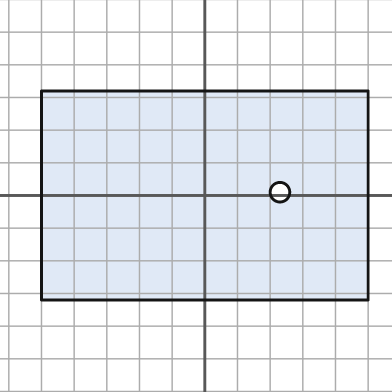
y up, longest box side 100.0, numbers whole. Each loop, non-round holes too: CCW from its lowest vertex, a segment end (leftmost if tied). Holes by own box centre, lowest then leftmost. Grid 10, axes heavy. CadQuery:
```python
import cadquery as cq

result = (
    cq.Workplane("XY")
    .moveTo(-50.0, -32.0)
    .lineTo(50.0, -32.0)
    .lineTo(50.0, 32.0)
    .lineTo(-50.0, 32.0)
    .close()
    .moveTo(23.0, 1.0)
    .circle(3.0)
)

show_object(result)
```